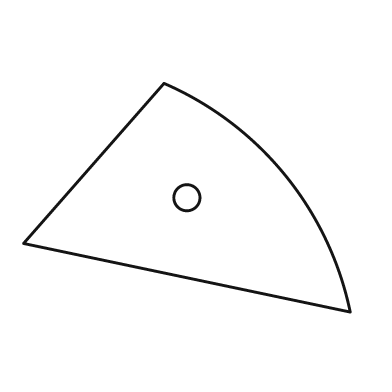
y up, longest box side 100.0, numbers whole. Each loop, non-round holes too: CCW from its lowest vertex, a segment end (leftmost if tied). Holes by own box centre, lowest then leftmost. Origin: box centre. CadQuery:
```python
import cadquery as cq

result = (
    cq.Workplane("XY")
    .moveTo(50.0, -35.0)
    .threePointArc((30.0, 7.0), (-7.0, 35.0))
    .lineTo(-50.0, -14.0)
    .close()
    .moveTo(0.0, 0.0)
    .circle(4.0)
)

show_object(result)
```